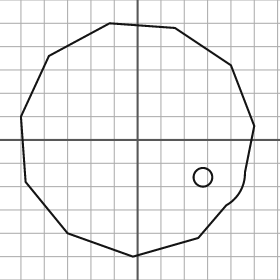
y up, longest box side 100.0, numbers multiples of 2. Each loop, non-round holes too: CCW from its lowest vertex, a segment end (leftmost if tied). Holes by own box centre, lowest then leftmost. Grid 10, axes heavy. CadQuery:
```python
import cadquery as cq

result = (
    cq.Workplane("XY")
    .moveTo(-2.0, -50.0)
    .lineTo(26.0, -42.0)
    .lineTo(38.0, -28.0)
    .threePointArc((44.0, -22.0), (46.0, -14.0))
    .lineTo(50.0, 6.0)
    .lineTo(40.0, 32.0)
    .lineTo(16.0, 48.0)
    .lineTo(-12.0, 50.0)
    .lineTo(-38.0, 36.0)
    .lineTo(-50.0, 10.0)
    .lineTo(-48.0, -18.0)
    .lineTo(-30.0, -40.0)
    .close()
    .moveTo(28.0, -16.0)
    .circle(4.0)
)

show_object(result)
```